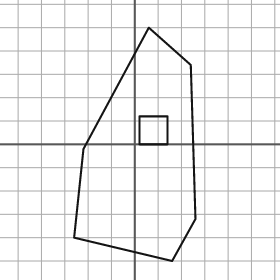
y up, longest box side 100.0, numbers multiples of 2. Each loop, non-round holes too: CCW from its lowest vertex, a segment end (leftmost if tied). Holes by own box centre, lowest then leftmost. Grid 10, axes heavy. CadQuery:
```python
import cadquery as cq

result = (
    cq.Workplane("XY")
    .moveTo(16.0, -50.0)
    .lineTo(26.0, -32.0)
    .lineTo(24.0, 34.0)
    .lineTo(6.0, 50.0)
    .lineTo(-22.0, -2.0)
    .lineTo(-26.0, -40.0)
    .close()
    .moveTo(2.0, 0.0)
    .lineTo(14.0, 0.0)
    .lineTo(14.0, 12.0)
    .lineTo(2.0, 12.0)
    .close()
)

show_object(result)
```